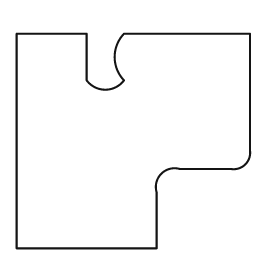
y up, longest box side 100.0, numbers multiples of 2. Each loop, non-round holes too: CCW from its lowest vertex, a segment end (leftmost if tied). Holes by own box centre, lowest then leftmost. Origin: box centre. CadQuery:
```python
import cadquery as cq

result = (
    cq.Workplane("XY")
    .moveTo(-50.0, -46.0)
    .lineTo(10.0, -46.0)
    .lineTo(10.0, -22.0)
    .threePointArc((12.0, -14.0), (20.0, -12.0))
    .lineTo(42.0, -12.0)
    .threePointArc((48.0, -10.0), (50.0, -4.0))
    .lineTo(50.0, 46.0)
    .lineTo(-4.0, 46.0)
    .threePointArc((-8.0, 36.0), (-4.0, 26.0))
    .threePointArc((-12.0, 22.0), (-20.0, 26.0))
    .lineTo(-20.0, 46.0)
    .lineTo(-50.0, 46.0)
    .close()
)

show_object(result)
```